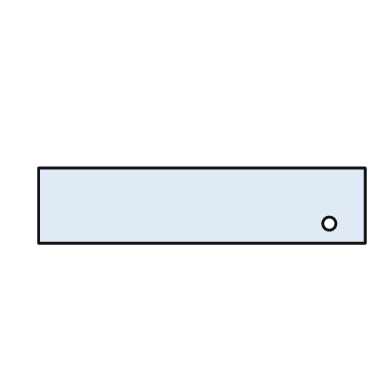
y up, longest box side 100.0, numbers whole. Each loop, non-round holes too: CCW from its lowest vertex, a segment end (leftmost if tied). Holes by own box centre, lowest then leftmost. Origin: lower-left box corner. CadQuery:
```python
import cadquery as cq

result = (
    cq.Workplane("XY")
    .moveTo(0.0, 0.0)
    .lineTo(100.0, 0.0)
    .lineTo(100.0, 23.0)
    .lineTo(0.0, 23.0)
    .close()
    .moveTo(89.0, 6.0)
    .circle(2.0)
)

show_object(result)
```